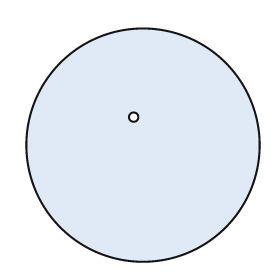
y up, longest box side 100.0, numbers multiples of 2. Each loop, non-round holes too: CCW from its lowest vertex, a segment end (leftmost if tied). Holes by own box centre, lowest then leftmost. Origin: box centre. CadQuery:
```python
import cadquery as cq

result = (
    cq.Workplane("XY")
    .moveTo(0.0, 0.0)
    .circle(50.0)
    .moveTo(-4.0, 12.0)
    .circle(2.0)
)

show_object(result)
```